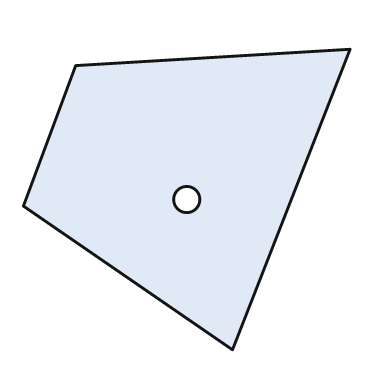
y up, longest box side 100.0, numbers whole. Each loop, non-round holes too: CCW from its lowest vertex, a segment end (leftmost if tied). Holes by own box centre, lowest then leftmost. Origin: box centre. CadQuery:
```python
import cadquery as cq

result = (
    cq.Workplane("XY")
    .moveTo(14.0, -46.0)
    .lineTo(50.0, 46.0)
    .lineTo(-34.0, 41.0)
    .lineTo(-50.0, -2.0)
    .close()
    .moveTo(0.0, 0.0)
    .circle(4.0)
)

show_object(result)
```